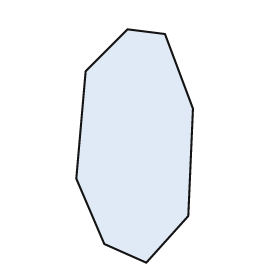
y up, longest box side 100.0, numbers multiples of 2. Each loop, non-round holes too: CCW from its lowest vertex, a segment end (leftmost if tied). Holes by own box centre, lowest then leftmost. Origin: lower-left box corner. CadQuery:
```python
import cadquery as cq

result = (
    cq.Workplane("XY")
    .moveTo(30.0, 0.0)
    .lineTo(48.0, 20.0)
    .lineTo(50.0, 66.0)
    .lineTo(38.0, 98.0)
    .lineTo(22.0, 100.0)
    .lineTo(4.0, 82.0)
    .lineTo(0.0, 36.0)
    .lineTo(12.0, 8.0)
    .close()
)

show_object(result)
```